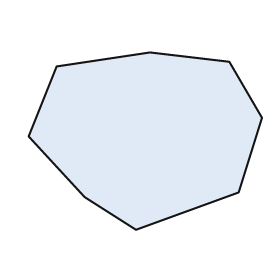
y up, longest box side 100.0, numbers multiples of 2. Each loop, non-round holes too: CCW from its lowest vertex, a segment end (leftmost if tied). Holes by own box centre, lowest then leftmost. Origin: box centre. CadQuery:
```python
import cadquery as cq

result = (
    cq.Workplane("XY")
    .moveTo(-4.0, -38.0)
    .lineTo(40.0, -22.0)
    .lineTo(50.0, 10.0)
    .lineTo(36.0, 34.0)
    .lineTo(2.0, 38.0)
    .lineTo(-38.0, 32.0)
    .lineTo(-50.0, 2.0)
    .lineTo(-26.0, -24.0)
    .close()
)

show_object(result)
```